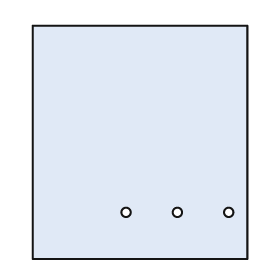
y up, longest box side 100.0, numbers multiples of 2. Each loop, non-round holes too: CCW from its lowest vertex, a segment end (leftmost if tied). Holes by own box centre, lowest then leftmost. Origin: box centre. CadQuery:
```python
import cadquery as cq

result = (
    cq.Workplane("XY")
    .moveTo(-46.0, -50.0)
    .lineTo(46.0, -50.0)
    .lineTo(46.0, 50.0)
    .lineTo(-46.0, 50.0)
    .close()
    .moveTo(-6.0, -30.0)
    .circle(2.0)
    .moveTo(16.0, -30.0)
    .circle(2.0)
    .moveTo(38.0, -30.0)
    .circle(2.0)
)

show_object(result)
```